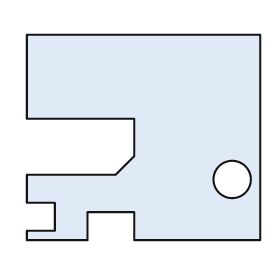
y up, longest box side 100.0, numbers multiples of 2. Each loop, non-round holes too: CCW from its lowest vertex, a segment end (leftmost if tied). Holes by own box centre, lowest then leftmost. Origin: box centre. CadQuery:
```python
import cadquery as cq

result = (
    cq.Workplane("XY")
    .moveTo(-50.0, -44.0)
    .lineTo(-24.0, -44.0)
    .lineTo(-24.0, -32.0)
    .lineTo(-4.0, -32.0)
    .lineTo(-4.0, -44.0)
    .lineTo(50.0, -44.0)
    .lineTo(50.0, 44.0)
    .lineTo(-50.0, 44.0)
    .lineTo(-50.0, 8.0)
    .lineTo(-4.0, 8.0)
    .lineTo(-4.0, -8.0)
    .lineTo(-12.0, -16.0)
    .lineTo(-50.0, -16.0)
    .lineTo(-50.0, -28.0)
    .lineTo(-38.0, -28.0)
    .lineTo(-38.0, -40.0)
    .lineTo(-50.0, -40.0)
    .close()
    .moveTo(38.0, -18.0)
    .circle(8.0)
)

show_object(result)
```